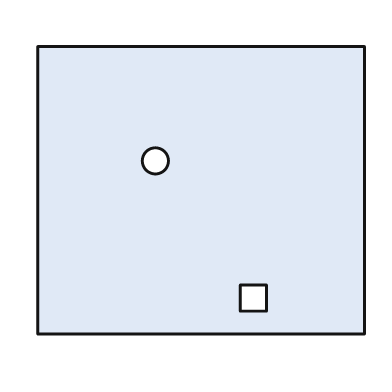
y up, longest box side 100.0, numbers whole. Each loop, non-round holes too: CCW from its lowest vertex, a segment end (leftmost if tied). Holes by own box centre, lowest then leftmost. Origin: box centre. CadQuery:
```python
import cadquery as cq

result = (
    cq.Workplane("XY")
    .moveTo(-50.0, -44.0)
    .lineTo(50.0, -44.0)
    .lineTo(50.0, 44.0)
    .lineTo(-50.0, 44.0)
    .close()
    .moveTo(12.0, -37.0)
    .lineTo(20.0, -37.0)
    .lineTo(20.0, -29.0)
    .lineTo(12.0, -29.0)
    .close()
    .moveTo(-14.0, 9.0)
    .circle(4.0)
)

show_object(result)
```